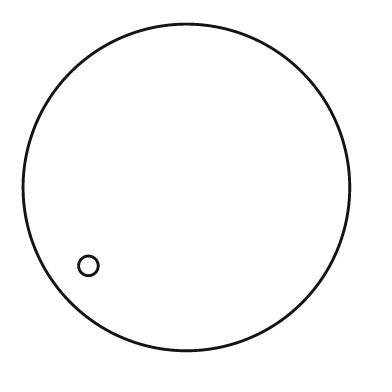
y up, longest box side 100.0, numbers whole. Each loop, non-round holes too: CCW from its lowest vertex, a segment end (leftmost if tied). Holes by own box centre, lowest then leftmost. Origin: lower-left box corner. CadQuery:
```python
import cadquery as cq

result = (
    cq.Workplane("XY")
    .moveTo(50.0, 50.0)
    .circle(50.0)
    .moveTo(20.0, 26.0)
    .circle(3.0)
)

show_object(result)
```